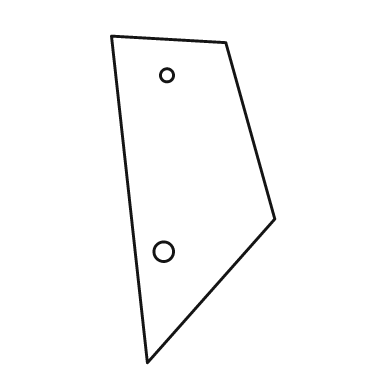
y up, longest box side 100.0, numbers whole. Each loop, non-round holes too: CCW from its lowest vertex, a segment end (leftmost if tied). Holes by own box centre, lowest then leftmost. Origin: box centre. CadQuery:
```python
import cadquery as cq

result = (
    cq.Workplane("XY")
    .moveTo(-14.0, -50.0)
    .lineTo(25.0, -6.0)
    .lineTo(10.0, 48.0)
    .lineTo(-25.0, 50.0)
    .close()
    .moveTo(-9.0, -16.0)
    .circle(3.0)
    .moveTo(-8.0, 38.0)
    .circle(2.0)
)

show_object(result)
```